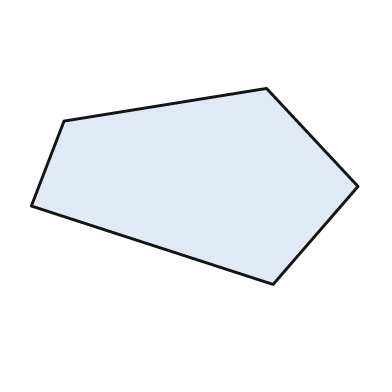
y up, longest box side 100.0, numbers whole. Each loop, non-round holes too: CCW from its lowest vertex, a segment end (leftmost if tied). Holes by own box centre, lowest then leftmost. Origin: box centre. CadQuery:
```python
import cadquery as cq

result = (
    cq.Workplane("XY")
    .moveTo(24.0, -30.0)
    .lineTo(50.0, 0.0)
    .lineTo(22.0, 30.0)
    .lineTo(-40.0, 20.0)
    .lineTo(-50.0, -6.0)
    .close()
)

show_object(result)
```